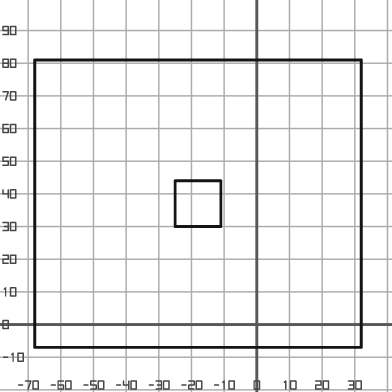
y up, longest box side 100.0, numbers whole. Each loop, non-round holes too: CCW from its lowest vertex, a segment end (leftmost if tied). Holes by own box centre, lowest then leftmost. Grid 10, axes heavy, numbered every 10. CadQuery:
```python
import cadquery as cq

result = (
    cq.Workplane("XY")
    .moveTo(-68.0, -7.0)
    .lineTo(32.0, -7.0)
    .lineTo(32.0, 81.0)
    .lineTo(-68.0, 81.0)
    .close()
    .moveTo(-25.0, 30.0)
    .lineTo(-11.0, 30.0)
    .lineTo(-11.0, 44.0)
    .lineTo(-25.0, 44.0)
    .close()
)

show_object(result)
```